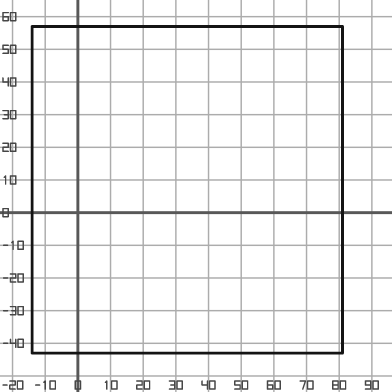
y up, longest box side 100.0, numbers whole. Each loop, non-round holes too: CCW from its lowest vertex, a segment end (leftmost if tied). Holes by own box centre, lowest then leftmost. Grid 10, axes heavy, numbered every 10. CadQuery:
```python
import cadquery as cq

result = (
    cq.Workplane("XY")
    .moveTo(-14.0, -43.0)
    .lineTo(81.0, -43.0)
    .lineTo(81.0, 57.0)
    .lineTo(-14.0, 57.0)
    .close()
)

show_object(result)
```